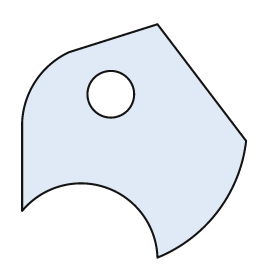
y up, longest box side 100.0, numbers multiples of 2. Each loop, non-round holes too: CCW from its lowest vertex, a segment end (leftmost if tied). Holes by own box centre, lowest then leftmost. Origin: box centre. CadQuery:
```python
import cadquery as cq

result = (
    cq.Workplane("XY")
    .moveTo(10.0, -50.0)
    .threePointArc((36.0, -30.0), (48.0, 0.0))
    .lineTo(10.0, 50.0)
    .lineTo(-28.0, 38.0)
    .threePointArc((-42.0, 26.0), (-48.0, 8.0))
    .lineTo(-48.0, -30.0)
    .threePointArc((-12.0, -20.0), (10.0, -50.0))
    .close()
    .moveTo(-10.0, 20.0)
    .circle(10.0)
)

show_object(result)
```